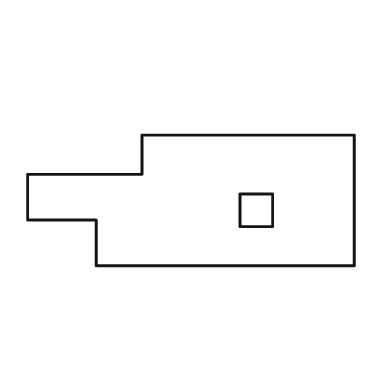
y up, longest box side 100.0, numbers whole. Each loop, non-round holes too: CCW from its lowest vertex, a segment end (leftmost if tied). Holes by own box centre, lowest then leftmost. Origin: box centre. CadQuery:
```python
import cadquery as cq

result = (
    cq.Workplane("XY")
    .moveTo(-29.0, -20.0)
    .lineTo(50.0, -20.0)
    .lineTo(50.0, 20.0)
    .lineTo(-15.0, 20.0)
    .lineTo(-15.0, 8.0)
    .lineTo(-50.0, 8.0)
    .lineTo(-50.0, -6.0)
    .lineTo(-29.0, -6.0)
    .close()
    .moveTo(15.0, -8.0)
    .lineTo(25.0, -8.0)
    .lineTo(25.0, 2.0)
    .lineTo(15.0, 2.0)
    .close()
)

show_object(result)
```